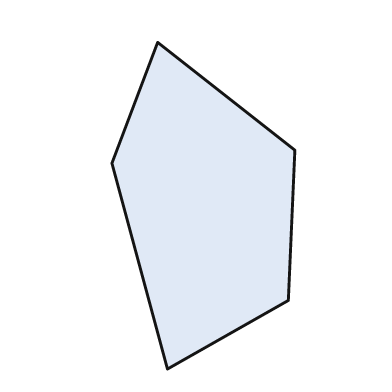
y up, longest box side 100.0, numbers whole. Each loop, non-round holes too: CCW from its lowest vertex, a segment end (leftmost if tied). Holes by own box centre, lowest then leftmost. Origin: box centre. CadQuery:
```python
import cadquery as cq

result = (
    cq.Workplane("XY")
    .moveTo(-11.0, -50.0)
    .lineTo(26.0, -29.0)
    .lineTo(28.0, 17.0)
    .lineTo(-14.0, 50.0)
    .lineTo(-28.0, 13.0)
    .close()
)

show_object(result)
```